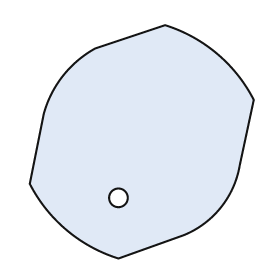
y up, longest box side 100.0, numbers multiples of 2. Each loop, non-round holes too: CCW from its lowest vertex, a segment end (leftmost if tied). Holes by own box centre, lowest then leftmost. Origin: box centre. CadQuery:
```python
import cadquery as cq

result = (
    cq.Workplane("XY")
    .moveTo(-10.0, -50.0)
    .lineTo(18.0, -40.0)
    .threePointArc((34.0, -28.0), (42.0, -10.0))
    .lineTo(48.0, 18.0)
    .threePointArc((32.0, 38.0), (10.0, 50.0))
    .lineTo(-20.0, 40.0)
    .threePointArc((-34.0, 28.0), (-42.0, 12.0))
    .lineTo(-48.0, -18.0)
    .threePointArc((-32.0, -38.0), (-10.0, -50.0))
    .close()
    .moveTo(-10.0, -24.0)
    .circle(4.0)
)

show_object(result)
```